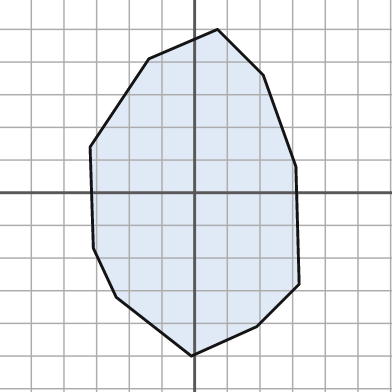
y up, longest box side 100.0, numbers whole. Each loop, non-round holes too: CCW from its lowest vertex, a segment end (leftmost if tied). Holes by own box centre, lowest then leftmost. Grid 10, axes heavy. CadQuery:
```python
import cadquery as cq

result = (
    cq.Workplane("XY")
    .moveTo(-1.0, -50.0)
    .lineTo(19.0, -41.0)
    .lineTo(32.0, -28.0)
    .lineTo(31.0, 8.0)
    .lineTo(21.0, 36.0)
    .lineTo(7.0, 50.0)
    .lineTo(-14.0, 41.0)
    .lineTo(-32.0, 14.0)
    .lineTo(-31.0, -17.0)
    .lineTo(-24.0, -32.0)
    .close()
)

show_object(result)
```